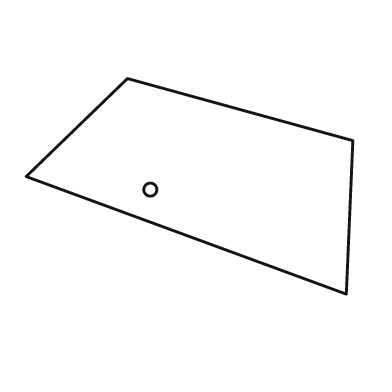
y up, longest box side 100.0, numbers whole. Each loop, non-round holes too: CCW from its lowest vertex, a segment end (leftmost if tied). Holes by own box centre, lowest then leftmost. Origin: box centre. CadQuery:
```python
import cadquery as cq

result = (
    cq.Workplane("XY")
    .moveTo(48.0, -33.0)
    .lineTo(50.0, 14.0)
    .lineTo(-19.0, 33.0)
    .lineTo(-50.0, 3.0)
    .close()
    .moveTo(-12.0, -1.0)
    .circle(2.0)
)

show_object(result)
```